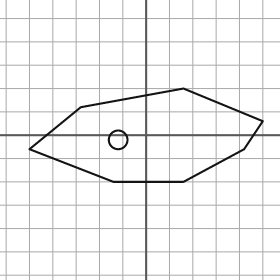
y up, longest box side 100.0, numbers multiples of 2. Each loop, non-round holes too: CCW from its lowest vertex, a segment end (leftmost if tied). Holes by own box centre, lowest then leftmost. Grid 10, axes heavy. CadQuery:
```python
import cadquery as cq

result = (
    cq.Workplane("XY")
    .moveTo(-14.0, -20.0)
    .lineTo(16.0, -20.0)
    .lineTo(42.0, -6.0)
    .lineTo(50.0, 6.0)
    .lineTo(16.0, 20.0)
    .lineTo(-28.0, 12.0)
    .lineTo(-50.0, -6.0)
    .close()
    .moveTo(-12.0, -2.0)
    .circle(4.0)
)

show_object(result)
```